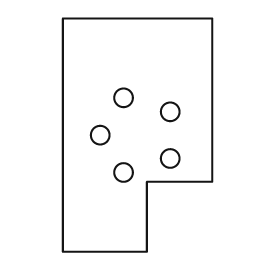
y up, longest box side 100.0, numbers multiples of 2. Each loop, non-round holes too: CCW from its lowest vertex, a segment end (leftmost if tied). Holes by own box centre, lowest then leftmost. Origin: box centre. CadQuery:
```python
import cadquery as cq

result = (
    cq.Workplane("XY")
    .moveTo(-32.0, -50.0)
    .lineTo(4.0, -50.0)
    .lineTo(4.0, -20.0)
    .lineTo(32.0, -20.0)
    .lineTo(32.0, 50.0)
    .lineTo(-32.0, 50.0)
    .close()
    .moveTo(-6.0, -16.0)
    .circle(4.0)
    .moveTo(14.0, -10.0)
    .circle(4.0)
    .moveTo(-16.0, 0.0)
    .circle(4.0)
    .moveTo(14.0, 10.0)
    .circle(4.0)
    .moveTo(-6.0, 16.0)
    .circle(4.0)
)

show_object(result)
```